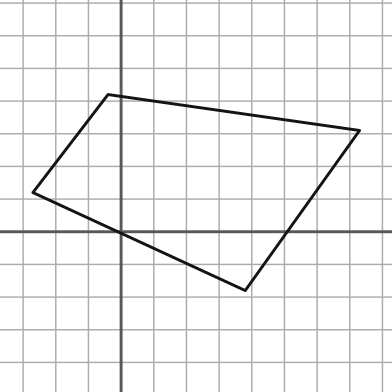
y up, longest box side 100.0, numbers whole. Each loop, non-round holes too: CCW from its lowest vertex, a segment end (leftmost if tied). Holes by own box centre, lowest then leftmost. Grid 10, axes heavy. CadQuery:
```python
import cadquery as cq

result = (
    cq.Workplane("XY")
    .moveTo(38.0, -18.0)
    .lineTo(73.0, 31.0)
    .lineTo(-4.0, 42.0)
    .lineTo(-27.0, 12.0)
    .close()
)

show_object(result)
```